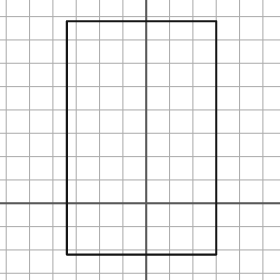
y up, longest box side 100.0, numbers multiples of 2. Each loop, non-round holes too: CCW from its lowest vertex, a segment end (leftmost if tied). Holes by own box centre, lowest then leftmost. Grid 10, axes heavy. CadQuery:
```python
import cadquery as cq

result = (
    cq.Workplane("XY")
    .moveTo(-34.0, -22.0)
    .lineTo(30.0, -22.0)
    .lineTo(30.0, 78.0)
    .lineTo(-34.0, 78.0)
    .close()
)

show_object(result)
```